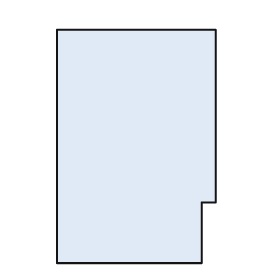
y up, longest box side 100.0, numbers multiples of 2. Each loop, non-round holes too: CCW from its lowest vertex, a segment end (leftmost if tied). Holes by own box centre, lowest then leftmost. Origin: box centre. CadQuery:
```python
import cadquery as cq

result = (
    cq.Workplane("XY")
    .moveTo(-34.0, -50.0)
    .lineTo(28.0, -50.0)
    .lineTo(28.0, -24.0)
    .lineTo(34.0, -24.0)
    .lineTo(34.0, 50.0)
    .lineTo(-34.0, 50.0)
    .close()
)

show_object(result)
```